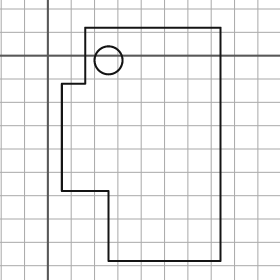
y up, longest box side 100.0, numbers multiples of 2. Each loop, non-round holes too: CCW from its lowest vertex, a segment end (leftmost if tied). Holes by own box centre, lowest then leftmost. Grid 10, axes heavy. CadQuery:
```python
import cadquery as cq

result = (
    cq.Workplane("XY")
    .moveTo(26.0, -88.0)
    .lineTo(74.0, -88.0)
    .lineTo(74.0, 12.0)
    .lineTo(16.0, 12.0)
    .lineTo(16.0, -12.0)
    .lineTo(6.0, -12.0)
    .lineTo(6.0, -58.0)
    .lineTo(26.0, -58.0)
    .close()
    .moveTo(26.0, -2.0)
    .circle(6.0)
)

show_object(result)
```